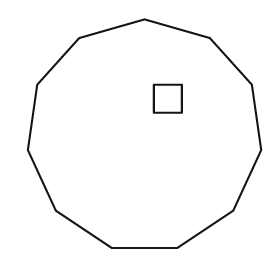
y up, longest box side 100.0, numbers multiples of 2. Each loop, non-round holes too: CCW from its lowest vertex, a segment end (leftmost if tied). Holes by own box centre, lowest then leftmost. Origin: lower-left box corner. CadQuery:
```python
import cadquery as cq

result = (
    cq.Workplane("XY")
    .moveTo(36.0, 0.0)
    .lineTo(64.0, 0.0)
    .lineTo(88.0, 16.0)
    .lineTo(100.0, 42.0)
    .lineTo(96.0, 70.0)
    .lineTo(78.0, 90.0)
    .lineTo(50.0, 98.0)
    .lineTo(22.0, 90.0)
    .lineTo(4.0, 70.0)
    .lineTo(0.0, 42.0)
    .lineTo(12.0, 16.0)
    .close()
    .moveTo(54.0, 58.0)
    .lineTo(66.0, 58.0)
    .lineTo(66.0, 70.0)
    .lineTo(54.0, 70.0)
    .close()
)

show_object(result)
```